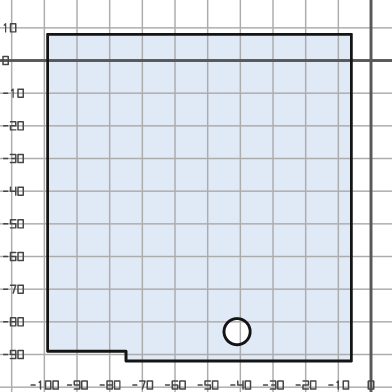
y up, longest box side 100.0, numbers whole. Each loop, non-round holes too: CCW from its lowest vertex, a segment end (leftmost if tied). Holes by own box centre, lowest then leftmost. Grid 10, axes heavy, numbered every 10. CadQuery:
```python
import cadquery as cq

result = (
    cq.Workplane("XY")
    .moveTo(-75.0, -92.0)
    .lineTo(-6.0, -92.0)
    .lineTo(-6.0, 8.0)
    .lineTo(-99.0, 8.0)
    .lineTo(-99.0, -89.0)
    .lineTo(-75.0, -89.0)
    .close()
    .moveTo(-41.0, -83.0)
    .circle(4.0)
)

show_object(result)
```